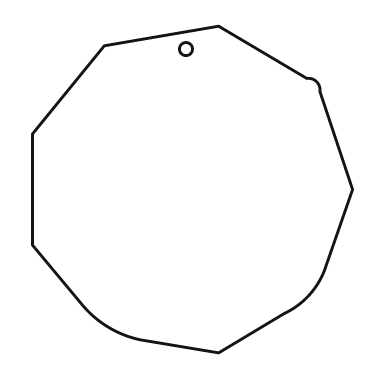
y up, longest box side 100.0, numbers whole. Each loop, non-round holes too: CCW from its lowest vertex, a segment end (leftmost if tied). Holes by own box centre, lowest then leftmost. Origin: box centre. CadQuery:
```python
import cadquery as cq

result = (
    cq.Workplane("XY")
    .moveTo(8.0, -50.0)
    .lineTo(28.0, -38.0)
    .threePointArc((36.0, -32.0), (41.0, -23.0))
    .lineTo(49.0, 0.0)
    .lineTo(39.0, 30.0)
    .threePointArc((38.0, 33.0), (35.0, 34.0))
    .lineTo(8.0, 50.0)
    .lineTo(-27.0, 44.0)
    .lineTo(-49.0, 17.0)
    .lineTo(-49.0, -17.0)
    .lineTo(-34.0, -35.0)
    .threePointArc((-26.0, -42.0), (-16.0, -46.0))
    .close()
    .moveTo(-2.0, 43.0)
    .circle(2.0)
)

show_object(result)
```